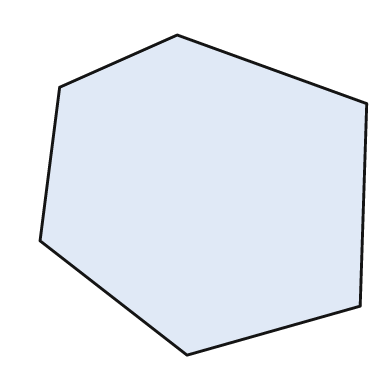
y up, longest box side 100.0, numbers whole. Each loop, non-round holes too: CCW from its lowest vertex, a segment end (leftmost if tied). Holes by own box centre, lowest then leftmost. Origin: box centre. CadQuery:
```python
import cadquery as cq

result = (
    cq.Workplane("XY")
    .moveTo(-5.0, -49.0)
    .lineTo(48.0, -34.0)
    .lineTo(50.0, 28.0)
    .lineTo(-8.0, 49.0)
    .lineTo(-44.0, 33.0)
    .lineTo(-50.0, -14.0)
    .close()
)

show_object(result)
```